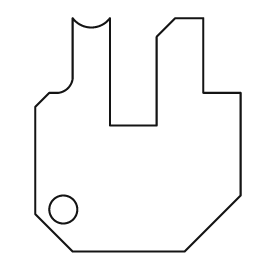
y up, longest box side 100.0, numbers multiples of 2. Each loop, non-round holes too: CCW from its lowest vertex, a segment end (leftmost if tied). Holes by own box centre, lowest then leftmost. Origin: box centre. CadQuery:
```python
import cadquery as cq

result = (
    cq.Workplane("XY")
    .moveTo(-28.0, -50.0)
    .lineTo(20.0, -50.0)
    .lineTo(44.0, -26.0)
    .lineTo(44.0, 18.0)
    .lineTo(28.0, 18.0)
    .lineTo(28.0, 50.0)
    .lineTo(16.0, 50.0)
    .lineTo(8.0, 42.0)
    .lineTo(8.0, 4.0)
    .lineTo(-12.0, 4.0)
    .lineTo(-12.0, 50.0)
    .threePointArc((-20.0, 46.0), (-28.0, 50.0))
    .lineTo(-28.0, 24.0)
    .threePointArc((-30.0, 20.0), (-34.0, 18.0))
    .lineTo(-38.0, 18.0)
    .lineTo(-44.0, 12.0)
    .lineTo(-44.0, -34.0)
    .close()
    .moveTo(-32.0, -32.0)
    .circle(6.0)
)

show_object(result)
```